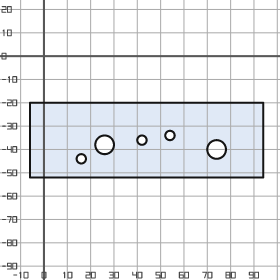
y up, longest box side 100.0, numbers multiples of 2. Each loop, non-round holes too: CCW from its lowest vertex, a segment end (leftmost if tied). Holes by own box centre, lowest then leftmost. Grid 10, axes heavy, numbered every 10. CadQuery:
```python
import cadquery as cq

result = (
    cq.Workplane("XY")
    .moveTo(-6.0, -52.0)
    .lineTo(94.0, -52.0)
    .lineTo(94.0, -20.0)
    .lineTo(-6.0, -20.0)
    .close()
    .moveTo(16.0, -44.0)
    .circle(2.0)
    .moveTo(74.0, -40.0)
    .circle(4.0)
    .moveTo(26.0, -38.0)
    .circle(4.0)
    .moveTo(42.0, -36.0)
    .circle(2.0)
    .moveTo(54.0, -34.0)
    .circle(2.0)
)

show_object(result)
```